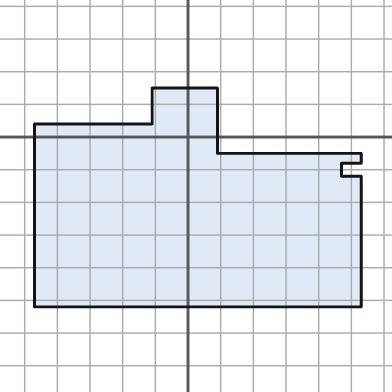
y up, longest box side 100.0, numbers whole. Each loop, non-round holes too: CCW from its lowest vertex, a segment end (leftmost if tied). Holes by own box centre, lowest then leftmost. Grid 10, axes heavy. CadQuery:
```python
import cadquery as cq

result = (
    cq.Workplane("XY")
    .moveTo(-47.0, -52.0)
    .lineTo(53.0, -52.0)
    .lineTo(53.0, -12.0)
    .lineTo(47.0, -12.0)
    .lineTo(47.0, -8.0)
    .lineTo(53.0, -8.0)
    .lineTo(53.0, -5.0)
    .lineTo(9.0, -5.0)
    .lineTo(9.0, 15.0)
    .lineTo(-11.0, 15.0)
    .lineTo(-11.0, 4.0)
    .lineTo(-47.0, 4.0)
    .close()
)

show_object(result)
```